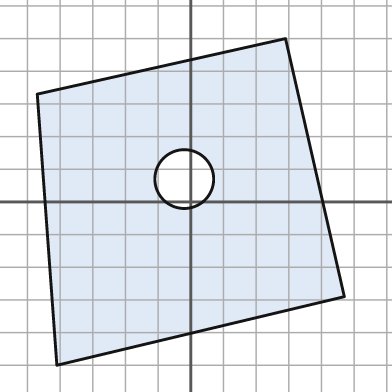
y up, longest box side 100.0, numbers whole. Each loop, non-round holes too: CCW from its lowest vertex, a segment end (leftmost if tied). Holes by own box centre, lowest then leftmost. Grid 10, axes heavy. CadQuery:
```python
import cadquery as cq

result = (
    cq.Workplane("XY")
    .moveTo(-41.0, -50.0)
    .lineTo(47.0, -29.0)
    .lineTo(29.0, 50.0)
    .lineTo(-47.0, 33.0)
    .close()
    .moveTo(-2.0, 7.0)
    .circle(9.0)
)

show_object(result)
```